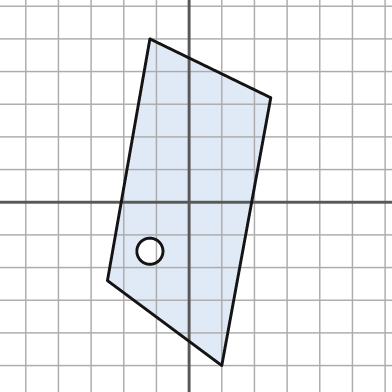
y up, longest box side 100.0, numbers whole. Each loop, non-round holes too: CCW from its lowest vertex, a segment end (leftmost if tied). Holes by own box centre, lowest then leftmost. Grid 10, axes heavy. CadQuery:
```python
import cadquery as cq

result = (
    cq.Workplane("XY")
    .moveTo(10.0, -50.0)
    .lineTo(25.0, 32.0)
    .lineTo(-12.0, 50.0)
    .lineTo(-25.0, -24.0)
    .close()
    .moveTo(-12.0, -15.0)
    .circle(4.0)
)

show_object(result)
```